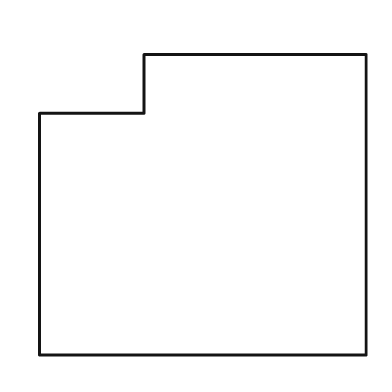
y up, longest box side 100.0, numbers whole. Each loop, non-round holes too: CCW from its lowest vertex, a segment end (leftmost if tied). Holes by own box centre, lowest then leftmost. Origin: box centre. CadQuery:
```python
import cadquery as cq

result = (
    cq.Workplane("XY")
    .moveTo(-50.0, -46.0)
    .lineTo(50.0, -46.0)
    .lineTo(50.0, 46.0)
    .lineTo(-18.0, 46.0)
    .lineTo(-18.0, 28.0)
    .lineTo(-50.0, 28.0)
    .close()
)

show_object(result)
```